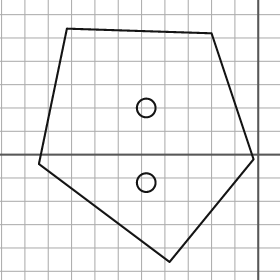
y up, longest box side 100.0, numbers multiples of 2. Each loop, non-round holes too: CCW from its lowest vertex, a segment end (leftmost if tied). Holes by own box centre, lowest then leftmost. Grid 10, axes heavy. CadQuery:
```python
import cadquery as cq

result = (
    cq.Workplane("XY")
    .moveTo(-38.0, -46.0)
    .lineTo(-2.0, -2.0)
    .lineTo(-20.0, 52.0)
    .lineTo(-82.0, 54.0)
    .lineTo(-94.0, -4.0)
    .close()
    .moveTo(-48.0, -12.0)
    .circle(4.0)
    .moveTo(-48.0, 20.0)
    .circle(4.0)
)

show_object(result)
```